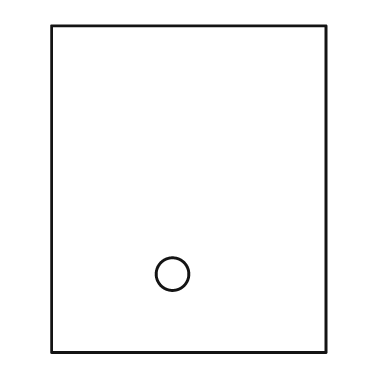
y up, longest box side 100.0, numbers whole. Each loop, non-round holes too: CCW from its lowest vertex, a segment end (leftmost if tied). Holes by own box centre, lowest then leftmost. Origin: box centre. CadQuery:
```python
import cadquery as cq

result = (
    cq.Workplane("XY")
    .moveTo(-42.0, -50.0)
    .lineTo(42.0, -50.0)
    .lineTo(42.0, 50.0)
    .lineTo(-42.0, 50.0)
    .close()
    .moveTo(-5.0, -26.0)
    .circle(5.0)
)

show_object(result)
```